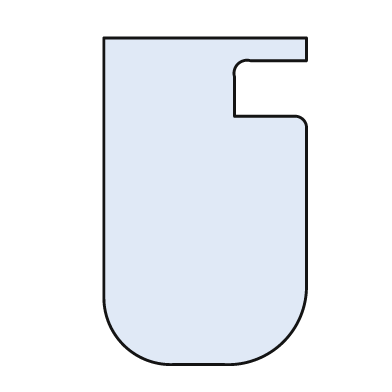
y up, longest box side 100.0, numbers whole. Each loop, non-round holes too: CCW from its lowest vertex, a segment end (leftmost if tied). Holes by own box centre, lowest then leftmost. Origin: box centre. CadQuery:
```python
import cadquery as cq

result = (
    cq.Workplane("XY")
    .moveTo(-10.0, -50.0)
    .lineTo(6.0, -50.0)
    .threePointArc((24.0, -43.0), (31.0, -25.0))
    .lineTo(31.0, 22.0)
    .threePointArc((30.0, 25.0), (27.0, 26.0))
    .lineTo(9.0, 26.0)
    .lineTo(9.0, 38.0)
    .threePointArc((10.0, 42.0), (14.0, 43.0))
    .lineTo(31.0, 43.0)
    .lineTo(31.0, 50.0)
    .lineTo(-31.0, 50.0)
    .lineTo(-31.0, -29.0)
    .threePointArc((-25.0, -44.0), (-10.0, -50.0))
    .close()
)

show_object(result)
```